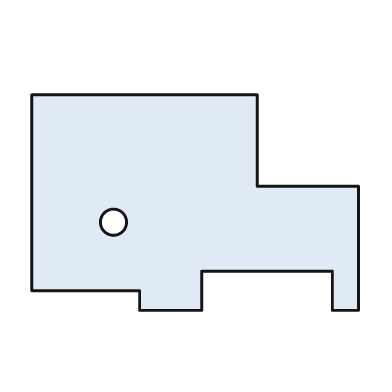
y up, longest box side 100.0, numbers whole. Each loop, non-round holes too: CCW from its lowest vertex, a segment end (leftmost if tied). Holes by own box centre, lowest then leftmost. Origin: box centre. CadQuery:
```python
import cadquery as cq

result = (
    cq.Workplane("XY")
    .moveTo(-17.0, -33.0)
    .lineTo(2.0, -33.0)
    .lineTo(2.0, -21.0)
    .lineTo(42.0, -21.0)
    .lineTo(42.0, -33.0)
    .lineTo(50.0, -33.0)
    .lineTo(50.0, 5.0)
    .lineTo(19.0, 5.0)
    .lineTo(19.0, 33.0)
    .lineTo(-50.0, 33.0)
    .lineTo(-50.0, -27.0)
    .lineTo(-17.0, -27.0)
    .close()
    .moveTo(-25.0, -6.0)
    .circle(4.0)
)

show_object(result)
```